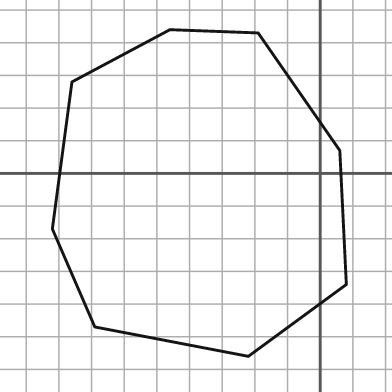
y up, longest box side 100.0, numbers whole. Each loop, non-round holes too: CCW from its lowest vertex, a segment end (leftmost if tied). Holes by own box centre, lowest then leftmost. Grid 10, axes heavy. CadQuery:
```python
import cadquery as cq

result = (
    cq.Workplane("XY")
    .moveTo(-22.0, -56.0)
    .lineTo(8.0, -34.0)
    .lineTo(6.0, 7.0)
    .lineTo(-19.0, 43.0)
    .lineTo(-46.0, 44.0)
    .lineTo(-76.0, 28.0)
    .lineTo(-82.0, -17.0)
    .lineTo(-69.0, -47.0)
    .close()
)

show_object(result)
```